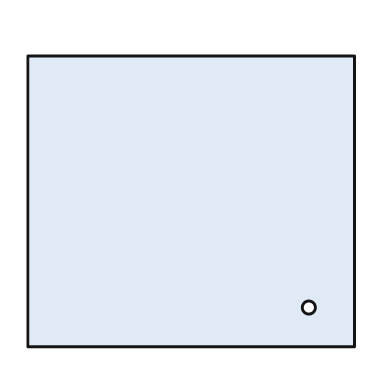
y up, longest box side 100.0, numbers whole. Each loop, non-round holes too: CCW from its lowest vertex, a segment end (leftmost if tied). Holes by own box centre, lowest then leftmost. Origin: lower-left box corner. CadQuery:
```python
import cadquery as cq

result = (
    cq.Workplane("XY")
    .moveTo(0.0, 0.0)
    .lineTo(100.0, 0.0)
    .lineTo(100.0, 89.0)
    .lineTo(0.0, 89.0)
    .close()
    .moveTo(86.0, 12.0)
    .circle(2.0)
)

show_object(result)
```